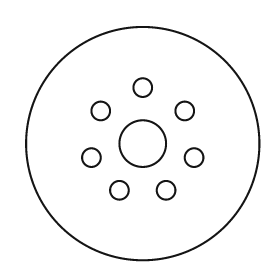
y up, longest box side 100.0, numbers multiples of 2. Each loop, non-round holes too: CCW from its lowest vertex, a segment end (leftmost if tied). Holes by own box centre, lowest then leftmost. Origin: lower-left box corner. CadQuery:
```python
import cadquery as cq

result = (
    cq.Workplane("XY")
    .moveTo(50.0, 50.0)
    .circle(50.0)
    .moveTo(40.0, 30.0)
    .circle(4.0)
    .moveTo(60.0, 30.0)
    .circle(4.0)
    .moveTo(28.0, 44.0)
    .circle(4.0)
    .moveTo(72.0, 44.0)
    .circle(4.0)
    .moveTo(50.0, 50.0)
    .circle(10.0)
    .moveTo(32.0, 64.0)
    .circle(4.0)
    .moveTo(68.0, 64.0)
    .circle(4.0)
    .moveTo(50.0, 74.0)
    .circle(4.0)
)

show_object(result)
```